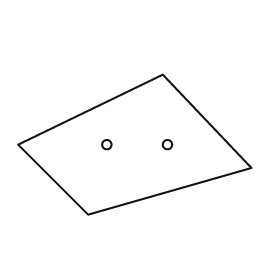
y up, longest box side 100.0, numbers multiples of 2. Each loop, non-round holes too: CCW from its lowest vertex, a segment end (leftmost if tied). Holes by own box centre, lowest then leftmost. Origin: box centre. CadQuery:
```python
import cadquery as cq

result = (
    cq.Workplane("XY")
    .moveTo(-20.0, -30.0)
    .lineTo(50.0, -10.0)
    .lineTo(12.0, 30.0)
    .lineTo(-50.0, 0.0)
    .close()
    .moveTo(-12.0, 0.0)
    .circle(2.0)
    .moveTo(14.0, 0.0)
    .circle(2.0)
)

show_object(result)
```